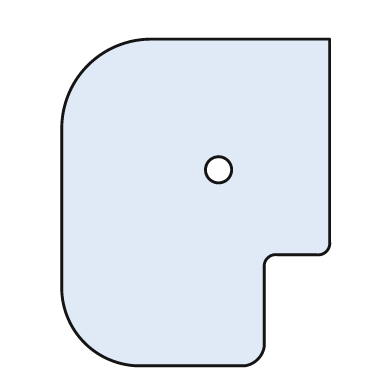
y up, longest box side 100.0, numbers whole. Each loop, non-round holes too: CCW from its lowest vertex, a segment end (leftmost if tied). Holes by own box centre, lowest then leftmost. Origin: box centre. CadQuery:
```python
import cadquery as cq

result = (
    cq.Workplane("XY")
    .moveTo(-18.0, -50.0)
    .lineTo(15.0, -50.0)
    .threePointArc((19.0, -48.0), (21.0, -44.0))
    .lineTo(21.0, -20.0)
    .threePointArc((22.0, -17.0), (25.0, -16.0))
    .lineTo(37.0, -16.0)
    .threePointArc((40.0, -15.0), (41.0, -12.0))
    .lineTo(41.0, 50.0)
    .lineTo(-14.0, 50.0)
    .threePointArc((-33.0, 42.0), (-41.0, 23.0))
    .lineTo(-41.0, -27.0)
    .threePointArc((-34.0, -43.0), (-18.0, -50.0))
    .close()
    .moveTo(7.0, 10.0)
    .circle(4.0)
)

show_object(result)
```